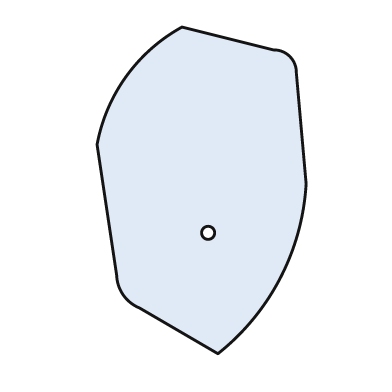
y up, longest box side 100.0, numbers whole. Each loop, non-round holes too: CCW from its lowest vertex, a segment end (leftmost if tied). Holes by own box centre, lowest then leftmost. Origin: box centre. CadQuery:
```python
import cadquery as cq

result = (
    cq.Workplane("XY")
    .moveTo(5.0, -50.0)
    .threePointArc((24.0, -27.0), (32.0, 2.0))
    .lineTo(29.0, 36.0)
    .threePointArc((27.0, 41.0), (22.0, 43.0))
    .lineTo(-6.0, 50.0)
    .threePointArc((-23.0, 35.0), (-32.0, 14.0))
    .lineTo(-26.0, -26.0)
    .threePointArc((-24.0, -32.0), (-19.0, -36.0))
    .close()
    .moveTo(2.0, -13.0)
    .circle(2.0)
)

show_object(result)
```